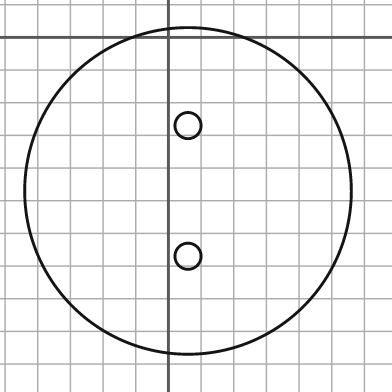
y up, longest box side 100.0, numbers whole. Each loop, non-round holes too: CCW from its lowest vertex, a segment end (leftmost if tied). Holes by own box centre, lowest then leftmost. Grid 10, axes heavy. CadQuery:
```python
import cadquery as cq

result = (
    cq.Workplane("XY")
    .moveTo(6.0, -47.0)
    .circle(50.0)
    .moveTo(6.0, -67.0)
    .circle(4.0)
    .moveTo(6.0, -27.0)
    .circle(4.0)
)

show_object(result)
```